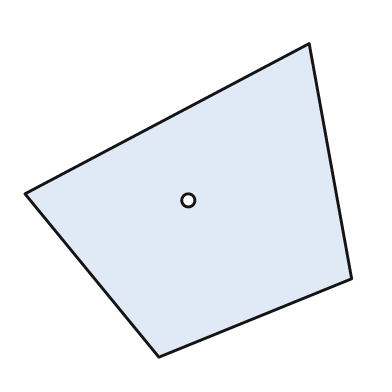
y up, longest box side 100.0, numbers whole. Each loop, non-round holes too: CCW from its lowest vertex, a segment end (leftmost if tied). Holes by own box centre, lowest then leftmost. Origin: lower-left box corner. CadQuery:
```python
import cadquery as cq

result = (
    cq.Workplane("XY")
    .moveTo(41.0, 0.0)
    .lineTo(100.0, 24.0)
    .lineTo(87.0, 96.0)
    .lineTo(0.0, 50.0)
    .close()
    .moveTo(50.0, 48.0)
    .circle(2.0)
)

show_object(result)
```